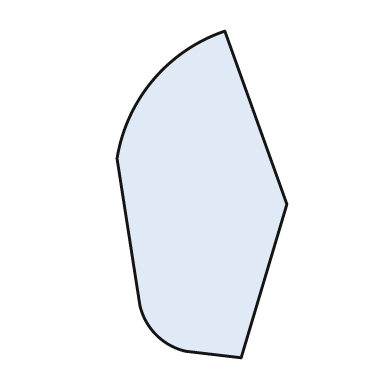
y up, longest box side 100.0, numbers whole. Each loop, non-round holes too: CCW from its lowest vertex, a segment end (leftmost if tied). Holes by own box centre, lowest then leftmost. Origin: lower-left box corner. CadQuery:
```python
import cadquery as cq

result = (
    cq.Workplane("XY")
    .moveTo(38.0, 0.0)
    .lineTo(52.0, 47.0)
    .lineTo(33.0, 100.0)
    .threePointArc((11.0, 85.0), (0.0, 61.0))
    .lineTo(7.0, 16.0)
    .threePointArc((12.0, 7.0), (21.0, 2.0))
    .close()
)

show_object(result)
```